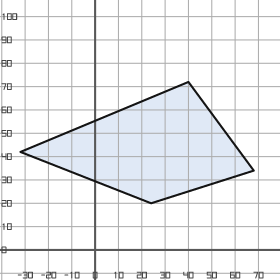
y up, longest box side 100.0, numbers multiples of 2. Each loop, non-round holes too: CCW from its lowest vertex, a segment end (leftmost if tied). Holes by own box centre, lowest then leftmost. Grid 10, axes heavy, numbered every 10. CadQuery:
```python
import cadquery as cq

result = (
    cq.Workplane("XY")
    .moveTo(24.0, 20.0)
    .lineTo(68.0, 34.0)
    .lineTo(40.0, 72.0)
    .lineTo(-32.0, 42.0)
    .close()
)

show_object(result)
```